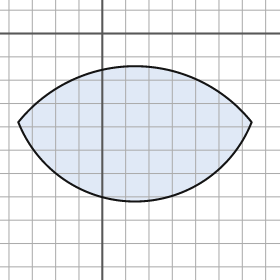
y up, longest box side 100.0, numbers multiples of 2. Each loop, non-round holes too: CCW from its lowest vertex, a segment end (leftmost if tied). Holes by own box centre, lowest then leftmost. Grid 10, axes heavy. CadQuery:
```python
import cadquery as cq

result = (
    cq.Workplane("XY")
    .moveTo(-36.0, -38.0)
    .threePointArc((14.0, -72.0), (64.0, -38.0))
    .threePointArc((14.0, -14.0), (-36.0, -38.0))
    .close()
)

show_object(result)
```